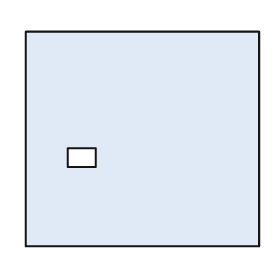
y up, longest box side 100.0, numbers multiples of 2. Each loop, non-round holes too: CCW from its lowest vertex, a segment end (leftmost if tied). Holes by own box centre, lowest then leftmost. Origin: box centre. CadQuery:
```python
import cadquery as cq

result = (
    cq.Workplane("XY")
    .moveTo(-50.0, -46.0)
    .lineTo(50.0, -46.0)
    .lineTo(50.0, 46.0)
    .lineTo(-50.0, 46.0)
    .close()
    .moveTo(-32.0, -12.0)
    .lineTo(-20.0, -12.0)
    .lineTo(-20.0, -4.0)
    .lineTo(-32.0, -4.0)
    .close()
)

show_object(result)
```